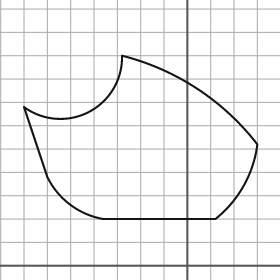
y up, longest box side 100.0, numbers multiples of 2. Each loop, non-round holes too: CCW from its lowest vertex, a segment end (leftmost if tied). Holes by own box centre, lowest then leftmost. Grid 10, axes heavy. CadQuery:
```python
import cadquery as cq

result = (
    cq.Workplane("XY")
    .moveTo(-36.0, 20.0)
    .lineTo(12.0, 20.0)
    .threePointArc((24.0, 34.0), (30.0, 52.0))
    .threePointArc((4.0, 76.0), (-28.0, 90.0))
    .threePointArc((-42.0, 66.0), (-70.0, 68.0))
    .lineTo(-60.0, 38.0)
    .threePointArc((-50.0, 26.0), (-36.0, 20.0))
    .close()
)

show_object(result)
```